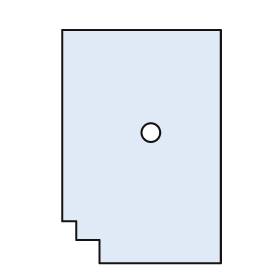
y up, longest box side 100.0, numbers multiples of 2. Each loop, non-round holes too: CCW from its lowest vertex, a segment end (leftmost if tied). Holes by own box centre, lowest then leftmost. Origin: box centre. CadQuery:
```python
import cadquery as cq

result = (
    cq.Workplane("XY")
    .moveTo(-18.0, -50.0)
    .lineTo(34.0, -50.0)
    .lineTo(34.0, 50.0)
    .lineTo(-34.0, 50.0)
    .lineTo(-34.0, -32.0)
    .lineTo(-28.0, -32.0)
    .lineTo(-28.0, -40.0)
    .lineTo(-18.0, -40.0)
    .close()
    .moveTo(4.0, 6.0)
    .circle(4.0)
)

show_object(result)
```